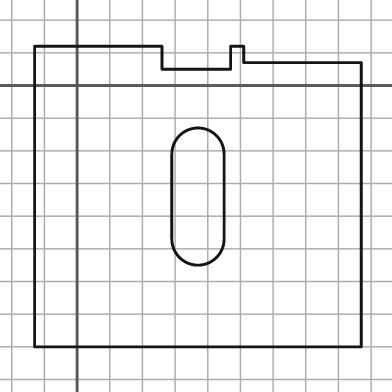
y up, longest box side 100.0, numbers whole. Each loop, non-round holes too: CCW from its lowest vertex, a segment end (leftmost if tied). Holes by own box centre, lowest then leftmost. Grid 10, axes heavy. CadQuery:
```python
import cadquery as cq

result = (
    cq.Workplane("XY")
    .moveTo(-13.0, -80.0)
    .lineTo(87.0, -80.0)
    .lineTo(87.0, 7.0)
    .lineTo(51.0, 7.0)
    .lineTo(51.0, 12.0)
    .lineTo(47.0, 12.0)
    .lineTo(47.0, 5.0)
    .lineTo(26.0, 5.0)
    .lineTo(26.0, 12.0)
    .lineTo(-13.0, 12.0)
    .close()
    .moveTo(29.0, -47.0)
    .threePointArc((37.0, -55.0), (45.0, -47.0))
    .lineTo(45.0, -21.0)
    .threePointArc((37.0, -13.0), (29.0, -21.0))
    .close()
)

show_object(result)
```